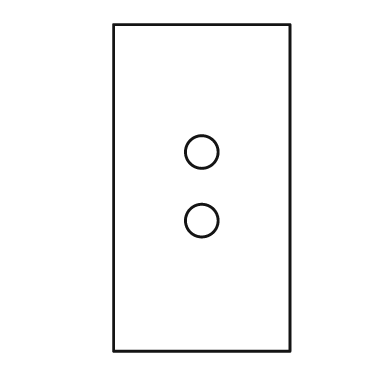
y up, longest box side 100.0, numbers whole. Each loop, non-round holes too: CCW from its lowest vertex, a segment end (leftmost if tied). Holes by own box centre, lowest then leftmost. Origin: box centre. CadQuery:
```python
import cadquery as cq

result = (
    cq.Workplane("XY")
    .moveTo(-27.0, -50.0)
    .lineTo(27.0, -50.0)
    .lineTo(27.0, 50.0)
    .lineTo(-27.0, 50.0)
    .close()
    .moveTo(0.0, -10.0)
    .circle(5.0)
    .moveTo(0.0, 11.0)
    .circle(5.0)
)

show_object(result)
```